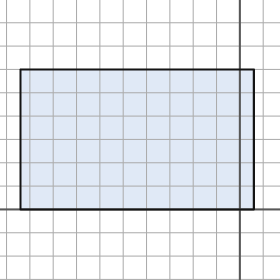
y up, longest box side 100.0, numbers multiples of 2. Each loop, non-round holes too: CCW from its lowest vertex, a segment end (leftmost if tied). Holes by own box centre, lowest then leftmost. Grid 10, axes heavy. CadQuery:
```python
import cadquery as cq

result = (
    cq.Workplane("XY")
    .moveTo(-94.0, 0.0)
    .lineTo(6.0, 0.0)
    .lineTo(6.0, 60.0)
    .lineTo(-94.0, 60.0)
    .close()
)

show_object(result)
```